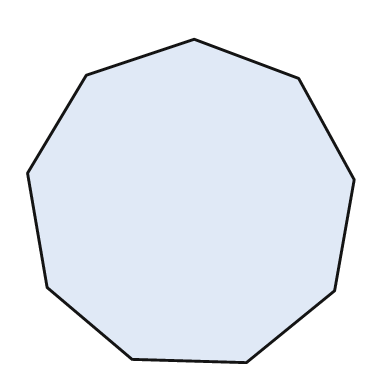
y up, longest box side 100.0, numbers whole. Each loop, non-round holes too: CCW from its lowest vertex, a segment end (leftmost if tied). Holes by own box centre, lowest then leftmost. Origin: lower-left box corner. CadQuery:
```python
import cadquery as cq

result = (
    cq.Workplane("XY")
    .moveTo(67.0, 0.0)
    .lineTo(94.0, 22.0)
    .lineTo(100.0, 56.0)
    .lineTo(83.0, 87.0)
    .lineTo(51.0, 99.0)
    .lineTo(18.0, 88.0)
    .lineTo(0.0, 58.0)
    .lineTo(6.0, 23.0)
    .lineTo(32.0, 1.0)
    .close()
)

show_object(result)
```